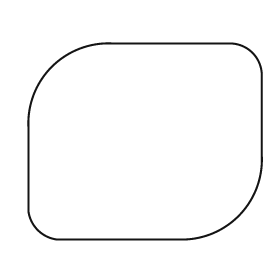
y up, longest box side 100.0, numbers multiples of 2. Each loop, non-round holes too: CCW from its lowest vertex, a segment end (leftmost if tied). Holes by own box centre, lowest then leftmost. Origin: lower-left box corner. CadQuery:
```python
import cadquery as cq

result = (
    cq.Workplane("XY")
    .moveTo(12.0, 0.0)
    .lineTo(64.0, 0.0)
    .threePointArc((90.0, 10.0), (100.0, 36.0))
    .lineTo(100.0, 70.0)
    .threePointArc((96.0, 80.0), (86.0, 84.0))
    .lineTo(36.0, 84.0)
    .threePointArc((10.0, 74.0), (0.0, 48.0))
    .lineTo(0.0, 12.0)
    .threePointArc((4.0, 4.0), (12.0, 0.0))
    .close()
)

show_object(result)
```